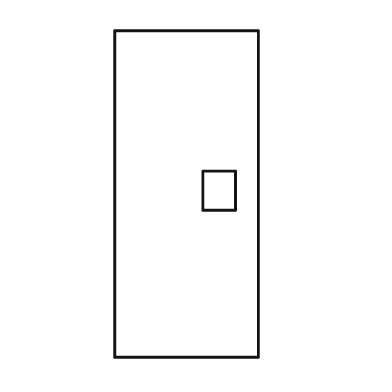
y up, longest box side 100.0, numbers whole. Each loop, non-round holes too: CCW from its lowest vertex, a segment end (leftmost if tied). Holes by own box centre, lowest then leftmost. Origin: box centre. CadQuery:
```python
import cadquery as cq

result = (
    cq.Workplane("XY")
    .moveTo(-22.0, -50.0)
    .lineTo(22.0, -50.0)
    .lineTo(22.0, 50.0)
    .lineTo(-22.0, 50.0)
    .close()
    .moveTo(5.0, -5.0)
    .lineTo(15.0, -5.0)
    .lineTo(15.0, 7.0)
    .lineTo(5.0, 7.0)
    .close()
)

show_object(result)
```